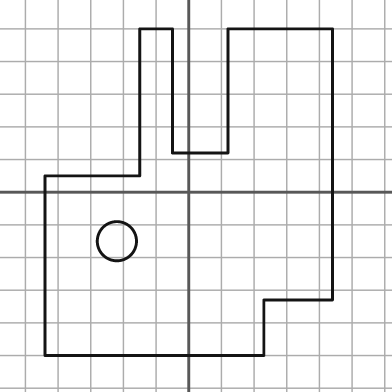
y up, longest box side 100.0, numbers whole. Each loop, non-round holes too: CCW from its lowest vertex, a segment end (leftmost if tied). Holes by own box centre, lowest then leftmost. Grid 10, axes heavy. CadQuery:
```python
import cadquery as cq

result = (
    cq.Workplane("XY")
    .moveTo(-44.0, -50.0)
    .lineTo(23.0, -50.0)
    .lineTo(23.0, -33.0)
    .lineTo(44.0, -33.0)
    .lineTo(44.0, 50.0)
    .lineTo(12.0, 50.0)
    .lineTo(12.0, 12.0)
    .lineTo(-5.0, 12.0)
    .lineTo(-5.0, 50.0)
    .lineTo(-15.0, 50.0)
    .lineTo(-15.0, 5.0)
    .lineTo(-44.0, 5.0)
    .close()
    .moveTo(-22.0, -15.0)
    .circle(6.0)
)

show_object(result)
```